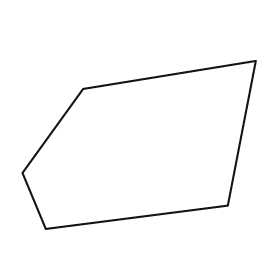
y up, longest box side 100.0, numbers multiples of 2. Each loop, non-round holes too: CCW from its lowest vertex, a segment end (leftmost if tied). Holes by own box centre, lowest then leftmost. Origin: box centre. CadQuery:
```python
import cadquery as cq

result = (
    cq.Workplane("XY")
    .moveTo(-40.0, -36.0)
    .lineTo(38.0, -26.0)
    .lineTo(50.0, 36.0)
    .lineTo(-24.0, 24.0)
    .lineTo(-50.0, -12.0)
    .close()
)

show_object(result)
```